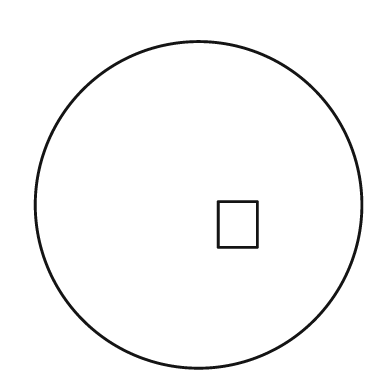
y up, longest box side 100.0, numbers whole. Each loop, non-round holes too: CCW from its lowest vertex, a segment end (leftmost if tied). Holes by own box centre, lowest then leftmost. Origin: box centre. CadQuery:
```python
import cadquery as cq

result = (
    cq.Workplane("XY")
    .moveTo(0.0, 0.0)
    .circle(50.0)
    .moveTo(6.0, -13.0)
    .lineTo(18.0, -13.0)
    .lineTo(18.0, 1.0)
    .lineTo(6.0, 1.0)
    .close()
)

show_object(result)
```